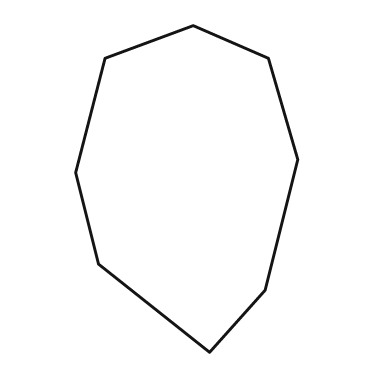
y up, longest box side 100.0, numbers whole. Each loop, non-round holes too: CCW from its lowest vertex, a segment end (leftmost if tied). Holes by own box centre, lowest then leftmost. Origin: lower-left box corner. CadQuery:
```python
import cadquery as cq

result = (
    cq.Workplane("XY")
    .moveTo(41.0, 0.0)
    .lineTo(58.0, 19.0)
    .lineTo(68.0, 59.0)
    .lineTo(59.0, 90.0)
    .lineTo(36.0, 100.0)
    .lineTo(9.0, 90.0)
    .lineTo(0.0, 55.0)
    .lineTo(7.0, 27.0)
    .close()
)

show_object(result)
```